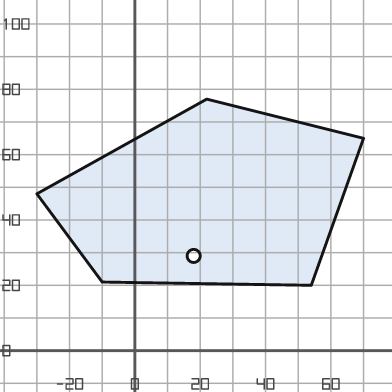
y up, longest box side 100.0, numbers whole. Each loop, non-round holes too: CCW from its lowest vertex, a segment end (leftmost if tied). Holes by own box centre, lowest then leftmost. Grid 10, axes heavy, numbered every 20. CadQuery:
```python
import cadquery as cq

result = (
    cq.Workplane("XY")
    .moveTo(54.0, 20.0)
    .lineTo(70.0, 65.0)
    .lineTo(22.0, 77.0)
    .lineTo(-30.0, 48.0)
    .lineTo(-10.0, 21.0)
    .close()
    .moveTo(18.0, 29.0)
    .circle(2.0)
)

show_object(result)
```